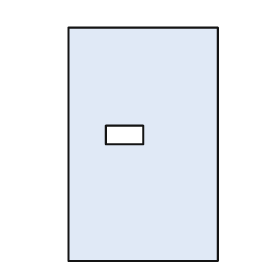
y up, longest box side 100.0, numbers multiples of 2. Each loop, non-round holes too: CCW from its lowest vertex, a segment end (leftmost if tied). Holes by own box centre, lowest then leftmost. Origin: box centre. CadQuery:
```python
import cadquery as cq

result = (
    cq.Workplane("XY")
    .moveTo(-32.0, -50.0)
    .lineTo(32.0, -50.0)
    .lineTo(32.0, 50.0)
    .lineTo(-32.0, 50.0)
    .close()
    .moveTo(-16.0, 0.0)
    .lineTo(0.0, 0.0)
    .lineTo(0.0, 8.0)
    .lineTo(-16.0, 8.0)
    .close()
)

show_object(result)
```